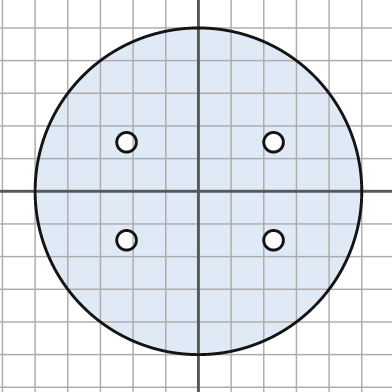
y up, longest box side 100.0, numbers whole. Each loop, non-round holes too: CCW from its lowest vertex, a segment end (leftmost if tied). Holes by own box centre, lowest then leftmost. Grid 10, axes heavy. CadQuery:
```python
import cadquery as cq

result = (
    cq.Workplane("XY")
    .moveTo(0.0, 0.0)
    .circle(50.0)
    .moveTo(-22.0, -15.0)
    .circle(3.0)
    .moveTo(23.0, -15.0)
    .circle(3.0)
    .moveTo(-22.0, 15.0)
    .circle(3.0)
    .moveTo(23.0, 15.0)
    .circle(3.0)
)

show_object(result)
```